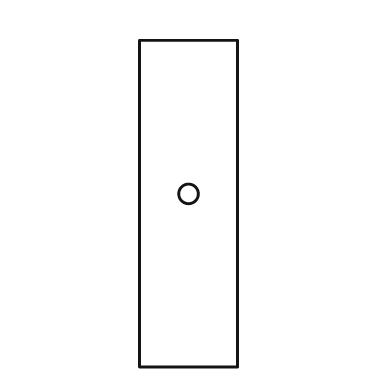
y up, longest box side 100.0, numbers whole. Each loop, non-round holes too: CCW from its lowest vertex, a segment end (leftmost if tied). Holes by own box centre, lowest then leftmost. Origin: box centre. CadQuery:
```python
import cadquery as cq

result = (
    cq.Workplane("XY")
    .moveTo(-15.0, -50.0)
    .lineTo(15.0, -50.0)
    .lineTo(15.0, 50.0)
    .lineTo(-15.0, 50.0)
    .close()
    .moveTo(0.0, 3.0)
    .circle(3.0)
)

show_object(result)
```